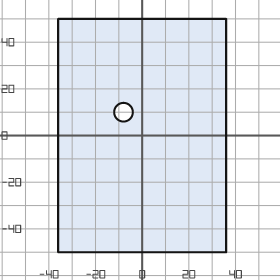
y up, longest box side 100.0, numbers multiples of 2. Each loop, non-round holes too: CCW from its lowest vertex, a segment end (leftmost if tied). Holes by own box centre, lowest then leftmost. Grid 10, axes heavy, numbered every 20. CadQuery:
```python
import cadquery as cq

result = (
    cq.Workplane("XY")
    .moveTo(-36.0, -50.0)
    .lineTo(36.0, -50.0)
    .lineTo(36.0, 50.0)
    .lineTo(-36.0, 50.0)
    .close()
    .moveTo(-8.0, 10.0)
    .circle(4.0)
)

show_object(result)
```